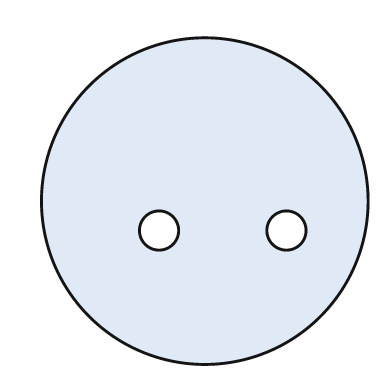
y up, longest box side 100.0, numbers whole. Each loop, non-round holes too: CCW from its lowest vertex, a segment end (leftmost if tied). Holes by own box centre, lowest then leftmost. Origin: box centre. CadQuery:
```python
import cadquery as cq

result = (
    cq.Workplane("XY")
    .moveTo(0.0, 0.0)
    .circle(50.0)
    .moveTo(-14.0, -9.0)
    .circle(6.0)
    .moveTo(25.0, -9.0)
    .circle(6.0)
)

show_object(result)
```